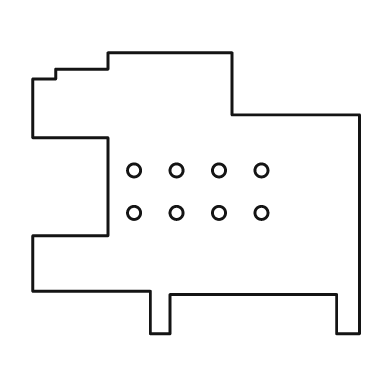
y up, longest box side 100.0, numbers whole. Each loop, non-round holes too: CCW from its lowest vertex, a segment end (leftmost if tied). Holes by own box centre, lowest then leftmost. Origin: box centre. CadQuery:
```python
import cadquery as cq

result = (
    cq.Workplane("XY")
    .moveTo(-14.0, -43.0)
    .lineTo(-8.0, -43.0)
    .lineTo(-8.0, -31.0)
    .lineTo(43.0, -31.0)
    .lineTo(43.0, -43.0)
    .lineTo(50.0, -43.0)
    .lineTo(50.0, 24.0)
    .lineTo(11.0, 24.0)
    .lineTo(11.0, 43.0)
    .lineTo(-27.0, 43.0)
    .lineTo(-27.0, 38.0)
    .lineTo(-43.0, 38.0)
    .lineTo(-43.0, 35.0)
    .lineTo(-50.0, 35.0)
    .lineTo(-50.0, 17.0)
    .lineTo(-27.0, 17.0)
    .lineTo(-27.0, -13.0)
    .lineTo(-50.0, -13.0)
    .lineTo(-50.0, -30.0)
    .lineTo(-14.0, -30.0)
    .close()
    .moveTo(-19.0, -6.0)
    .circle(2.0)
    .moveTo(-6.0, -6.0)
    .circle(2.0)
    .moveTo(7.0, -6.0)
    .circle(2.0)
    .moveTo(20.0, -6.0)
    .circle(2.0)
    .moveTo(-19.0, 7.0)
    .circle(2.0)
    .moveTo(-6.0, 7.0)
    .circle(2.0)
    .moveTo(7.0, 7.0)
    .circle(2.0)
    .moveTo(20.0, 7.0)
    .circle(2.0)
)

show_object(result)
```